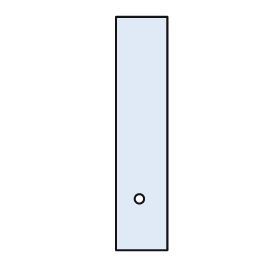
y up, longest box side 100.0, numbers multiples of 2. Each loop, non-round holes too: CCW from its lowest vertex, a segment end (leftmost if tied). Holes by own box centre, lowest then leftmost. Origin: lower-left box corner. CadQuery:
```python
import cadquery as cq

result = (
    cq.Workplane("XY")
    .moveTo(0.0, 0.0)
    .lineTo(22.0, 0.0)
    .lineTo(22.0, 100.0)
    .lineTo(0.0, 100.0)
    .close()
    .moveTo(10.0, 22.0)
    .circle(2.0)
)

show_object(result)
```